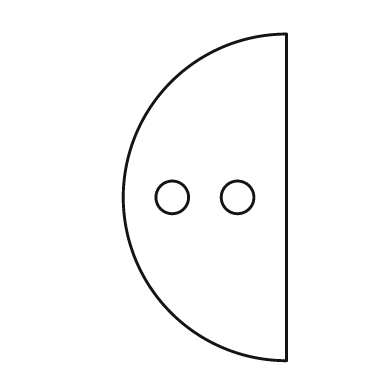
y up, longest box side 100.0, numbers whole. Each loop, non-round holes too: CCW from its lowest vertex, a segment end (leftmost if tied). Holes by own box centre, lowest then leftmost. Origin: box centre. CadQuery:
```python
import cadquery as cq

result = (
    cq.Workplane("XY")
    .moveTo(25.0, -50.0)
    .lineTo(25.0, 50.0)
    .threePointArc((-25.0, 0.0), (25.0, -50.0))
    .close()
    .moveTo(-10.0, 0.0)
    .circle(5.0)
    .moveTo(10.0, 0.0)
    .circle(5.0)
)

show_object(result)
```